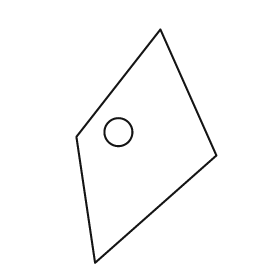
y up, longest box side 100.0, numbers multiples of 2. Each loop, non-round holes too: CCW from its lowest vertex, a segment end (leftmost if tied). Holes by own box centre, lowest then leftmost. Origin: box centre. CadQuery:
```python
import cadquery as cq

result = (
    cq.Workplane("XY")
    .moveTo(-22.0, -50.0)
    .lineTo(30.0, -4.0)
    .lineTo(6.0, 50.0)
    .lineTo(-30.0, 4.0)
    .close()
    .moveTo(-12.0, 6.0)
    .circle(6.0)
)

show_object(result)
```